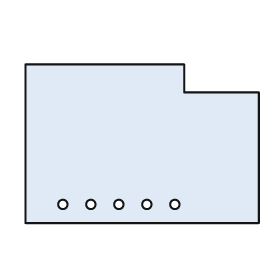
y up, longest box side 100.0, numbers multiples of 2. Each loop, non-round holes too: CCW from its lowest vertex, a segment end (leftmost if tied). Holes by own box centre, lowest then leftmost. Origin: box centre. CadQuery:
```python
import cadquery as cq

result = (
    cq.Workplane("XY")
    .moveTo(-50.0, -34.0)
    .lineTo(50.0, -34.0)
    .lineTo(50.0, 22.0)
    .lineTo(18.0, 22.0)
    .lineTo(18.0, 34.0)
    .lineTo(-50.0, 34.0)
    .close()
    .moveTo(-34.0, -26.0)
    .circle(2.0)
    .moveTo(-22.0, -26.0)
    .circle(2.0)
    .moveTo(-10.0, -26.0)
    .circle(2.0)
    .moveTo(2.0, -26.0)
    .circle(2.0)
    .moveTo(14.0, -26.0)
    .circle(2.0)
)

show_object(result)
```